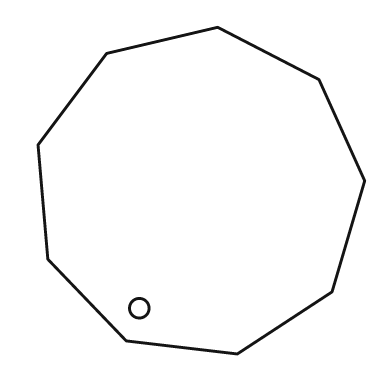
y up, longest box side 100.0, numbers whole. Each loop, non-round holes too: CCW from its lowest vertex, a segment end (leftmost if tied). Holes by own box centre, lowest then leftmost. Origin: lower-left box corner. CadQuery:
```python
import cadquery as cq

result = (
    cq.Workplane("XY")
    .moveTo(61.0, 0.0)
    .lineTo(90.0, 19.0)
    .lineTo(100.0, 53.0)
    .lineTo(86.0, 84.0)
    .lineTo(55.0, 100.0)
    .lineTo(21.0, 92.0)
    .lineTo(0.0, 64.0)
    .lineTo(3.0, 29.0)
    .lineTo(27.0, 4.0)
    .close()
    .moveTo(31.0, 14.0)
    .circle(3.0)
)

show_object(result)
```